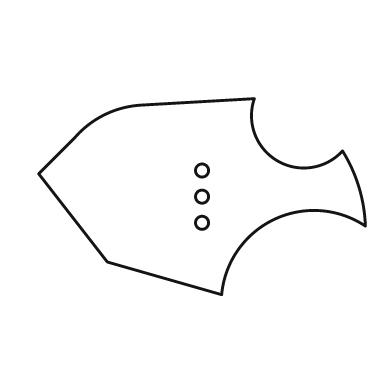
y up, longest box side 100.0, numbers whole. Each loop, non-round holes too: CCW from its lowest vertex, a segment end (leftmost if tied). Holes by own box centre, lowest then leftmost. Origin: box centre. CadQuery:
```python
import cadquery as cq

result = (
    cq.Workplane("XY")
    .moveTo(6.0, -30.0)
    .threePointArc((22.0, -7.0), (50.0, -9.0))
    .threePointArc((48.0, 3.0), (43.0, 14.0))
    .threePointArc((23.0, 11.0), (16.0, 30.0))
    .lineTo(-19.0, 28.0)
    .threePointArc((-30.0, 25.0), (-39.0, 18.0))
    .lineTo(-50.0, 7.0)
    .lineTo(-29.0, -20.0)
    .close()
    .moveTo(0.0, -8.0)
    .circle(2.0)
    .moveTo(0.0, 0.0)
    .circle(2.0)
    .moveTo(0.0, 8.0)
    .circle(2.0)
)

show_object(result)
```